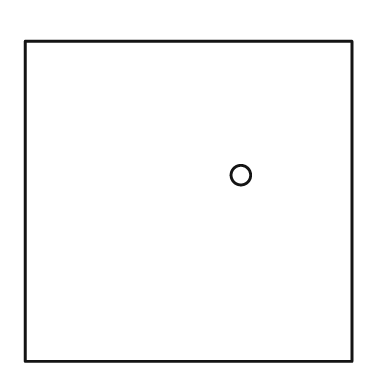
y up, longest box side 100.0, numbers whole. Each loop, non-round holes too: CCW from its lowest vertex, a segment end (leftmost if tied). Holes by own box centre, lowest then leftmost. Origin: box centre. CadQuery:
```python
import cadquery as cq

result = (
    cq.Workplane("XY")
    .moveTo(-50.0, -49.0)
    .lineTo(50.0, -49.0)
    .lineTo(50.0, 49.0)
    .lineTo(-50.0, 49.0)
    .close()
    .moveTo(16.0, 8.0)
    .circle(3.0)
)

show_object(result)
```